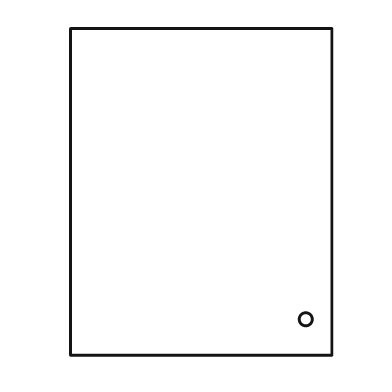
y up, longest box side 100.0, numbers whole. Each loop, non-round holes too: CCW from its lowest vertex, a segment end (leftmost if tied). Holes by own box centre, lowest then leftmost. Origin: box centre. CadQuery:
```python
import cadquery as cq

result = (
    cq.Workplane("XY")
    .moveTo(-40.0, -50.0)
    .lineTo(40.0, -50.0)
    .lineTo(40.0, 50.0)
    .lineTo(-40.0, 50.0)
    .close()
    .moveTo(32.0, -39.0)
    .circle(2.0)
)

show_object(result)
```